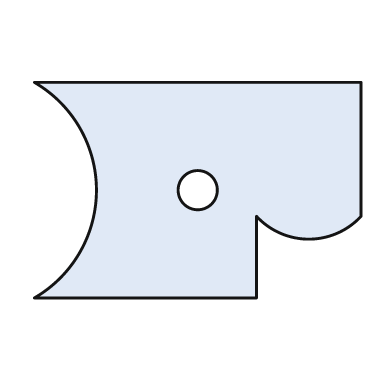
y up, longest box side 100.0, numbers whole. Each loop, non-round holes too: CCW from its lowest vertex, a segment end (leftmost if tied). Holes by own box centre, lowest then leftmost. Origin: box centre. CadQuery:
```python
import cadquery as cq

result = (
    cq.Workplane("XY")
    .moveTo(-50.0, -33.0)
    .lineTo(18.0, -33.0)
    .lineTo(18.0, -8.0)
    .threePointArc((34.0, -15.0), (50.0, -8.0))
    .lineTo(50.0, 33.0)
    .lineTo(-50.0, 33.0)
    .threePointArc((-31.0, 0.0), (-50.0, -33.0))
    .close()
    .moveTo(0.0, 0.0)
    .circle(6.0)
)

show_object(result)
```